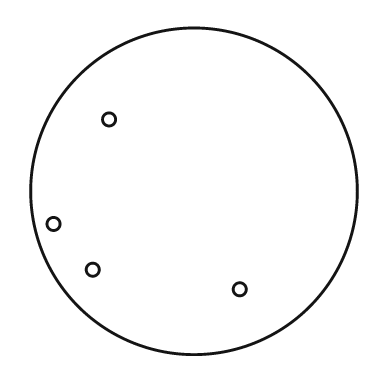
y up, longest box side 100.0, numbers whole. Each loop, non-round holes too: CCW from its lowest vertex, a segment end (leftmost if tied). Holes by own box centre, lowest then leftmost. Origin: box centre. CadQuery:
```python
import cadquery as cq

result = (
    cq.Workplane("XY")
    .moveTo(0.0, 0.0)
    .circle(50.0)
    .moveTo(14.0, -30.0)
    .circle(2.0)
    .moveTo(-31.0, -24.0)
    .circle(2.0)
    .moveTo(-43.0, -10.0)
    .circle(2.0)
    .moveTo(-26.0, 22.0)
    .circle(2.0)
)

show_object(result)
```